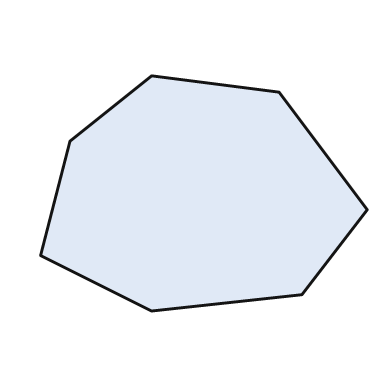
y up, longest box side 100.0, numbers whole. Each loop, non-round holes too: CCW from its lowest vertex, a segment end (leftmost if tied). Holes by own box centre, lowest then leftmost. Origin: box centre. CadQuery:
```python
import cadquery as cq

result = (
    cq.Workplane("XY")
    .moveTo(-16.0, -36.0)
    .lineTo(30.0, -31.0)
    .lineTo(50.0, -5.0)
    .lineTo(23.0, 31.0)
    .lineTo(-16.0, 36.0)
    .lineTo(-41.0, 16.0)
    .lineTo(-50.0, -19.0)
    .close()
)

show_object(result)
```